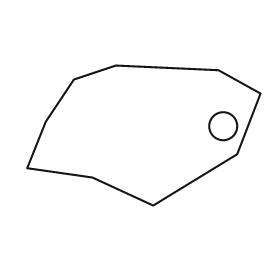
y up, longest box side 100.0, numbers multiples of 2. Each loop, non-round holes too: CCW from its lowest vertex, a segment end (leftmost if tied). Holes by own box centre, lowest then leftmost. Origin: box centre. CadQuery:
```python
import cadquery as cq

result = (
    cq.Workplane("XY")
    .moveTo(4.0, -30.0)
    .lineTo(40.0, -8.0)
    .lineTo(50.0, 18.0)
    .lineTo(32.0, 28.0)
    .lineTo(-12.0, 30.0)
    .lineTo(-30.0, 24.0)
    .lineTo(-42.0, 6.0)
    .lineTo(-50.0, -14.0)
    .lineTo(-22.0, -18.0)
    .close()
    .moveTo(34.0, 4.0)
    .circle(6.0)
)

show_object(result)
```